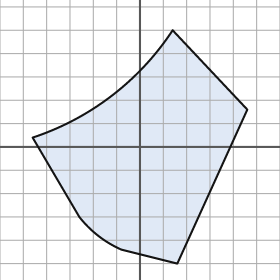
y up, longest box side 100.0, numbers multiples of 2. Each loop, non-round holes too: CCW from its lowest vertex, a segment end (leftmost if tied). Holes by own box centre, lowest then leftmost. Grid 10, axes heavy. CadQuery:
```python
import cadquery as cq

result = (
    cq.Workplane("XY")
    .moveTo(16.0, -50.0)
    .lineTo(46.0, 16.0)
    .lineTo(14.0, 50.0)
    .threePointArc((-12.0, 22.0), (-46.0, 4.0))
    .lineTo(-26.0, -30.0)
    .threePointArc((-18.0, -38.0), (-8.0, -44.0))
    .close()
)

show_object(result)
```